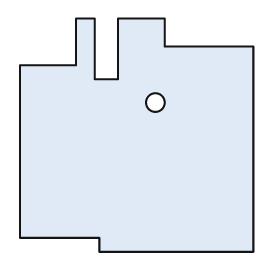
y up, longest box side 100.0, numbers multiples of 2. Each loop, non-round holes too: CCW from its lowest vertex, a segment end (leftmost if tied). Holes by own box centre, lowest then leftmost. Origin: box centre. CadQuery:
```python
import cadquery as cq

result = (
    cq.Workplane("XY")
    .moveTo(-16.0, -50.0)
    .lineTo(50.0, -50.0)
    .lineTo(50.0, 38.0)
    .lineTo(12.0, 38.0)
    .lineTo(12.0, 50.0)
    .lineTo(-8.0, 50.0)
    .lineTo(-8.0, 24.0)
    .lineTo(-18.0, 24.0)
    .lineTo(-18.0, 50.0)
    .lineTo(-26.0, 50.0)
    .lineTo(-26.0, 30.0)
    .lineTo(-50.0, 30.0)
    .lineTo(-50.0, -44.0)
    .lineTo(-16.0, -44.0)
    .close()
    .moveTo(8.0, 14.0)
    .circle(4.0)
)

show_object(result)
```